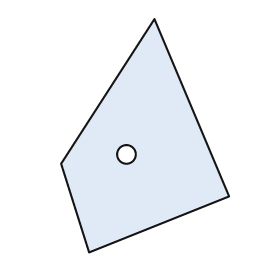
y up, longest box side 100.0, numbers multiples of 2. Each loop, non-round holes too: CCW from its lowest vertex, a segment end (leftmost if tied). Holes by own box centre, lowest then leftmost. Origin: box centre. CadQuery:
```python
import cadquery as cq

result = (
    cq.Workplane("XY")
    .moveTo(-24.0, -50.0)
    .lineTo(36.0, -26.0)
    .lineTo(4.0, 50.0)
    .lineTo(-36.0, -12.0)
    .close()
    .moveTo(-8.0, -8.0)
    .circle(4.0)
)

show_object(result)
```